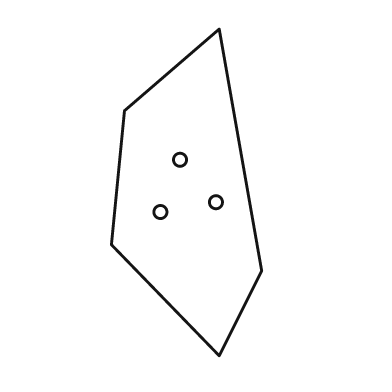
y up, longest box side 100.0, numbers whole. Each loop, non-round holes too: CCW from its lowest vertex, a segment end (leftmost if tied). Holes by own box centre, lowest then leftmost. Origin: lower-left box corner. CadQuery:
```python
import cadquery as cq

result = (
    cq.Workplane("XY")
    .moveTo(33.0, 0.0)
    .lineTo(46.0, 26.0)
    .lineTo(33.0, 100.0)
    .lineTo(4.0, 75.0)
    .lineTo(0.0, 34.0)
    .close()
    .moveTo(15.0, 44.0)
    .circle(2.0)
    .moveTo(32.0, 47.0)
    .circle(2.0)
    .moveTo(21.0, 60.0)
    .circle(2.0)
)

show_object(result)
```